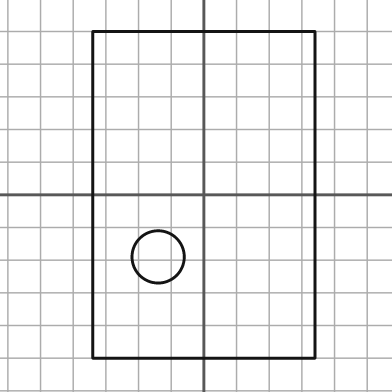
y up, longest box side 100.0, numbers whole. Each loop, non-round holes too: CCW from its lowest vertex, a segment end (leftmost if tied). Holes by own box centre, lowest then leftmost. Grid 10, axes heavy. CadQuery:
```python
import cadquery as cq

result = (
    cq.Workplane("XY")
    .moveTo(-34.0, -50.0)
    .lineTo(34.0, -50.0)
    .lineTo(34.0, 50.0)
    .lineTo(-34.0, 50.0)
    .close()
    .moveTo(-14.0, -19.0)
    .circle(8.0)
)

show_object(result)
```